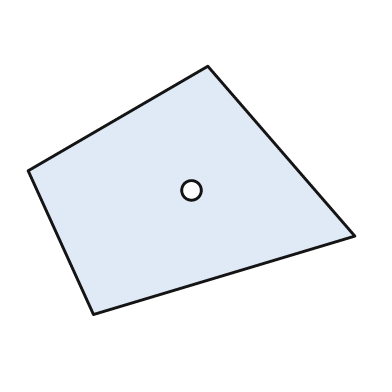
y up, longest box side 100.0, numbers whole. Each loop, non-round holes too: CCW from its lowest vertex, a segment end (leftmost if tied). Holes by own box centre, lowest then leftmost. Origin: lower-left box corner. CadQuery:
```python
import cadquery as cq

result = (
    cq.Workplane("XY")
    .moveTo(20.0, 0.0)
    .lineTo(100.0, 24.0)
    .lineTo(55.0, 76.0)
    .lineTo(0.0, 44.0)
    .close()
    .moveTo(50.0, 38.0)
    .circle(3.0)
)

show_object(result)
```